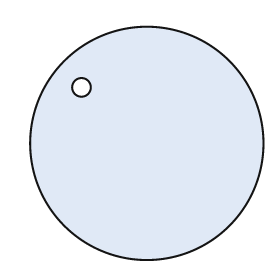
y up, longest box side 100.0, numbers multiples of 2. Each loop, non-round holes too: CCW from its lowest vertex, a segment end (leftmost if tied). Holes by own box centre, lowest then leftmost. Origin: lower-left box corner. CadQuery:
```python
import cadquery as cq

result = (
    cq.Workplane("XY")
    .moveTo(50.0, 50.0)
    .circle(50.0)
    .moveTo(22.0, 74.0)
    .circle(4.0)
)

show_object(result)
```